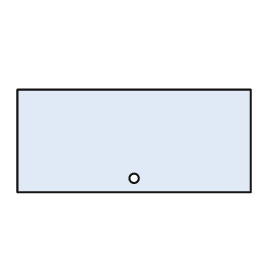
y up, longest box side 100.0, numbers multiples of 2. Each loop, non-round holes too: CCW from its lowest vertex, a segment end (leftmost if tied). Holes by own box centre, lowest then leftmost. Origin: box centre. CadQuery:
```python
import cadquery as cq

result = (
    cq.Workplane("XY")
    .moveTo(-50.0, -22.0)
    .lineTo(50.0, -22.0)
    .lineTo(50.0, 22.0)
    .lineTo(-50.0, 22.0)
    .close()
    .moveTo(0.0, -16.0)
    .circle(2.0)
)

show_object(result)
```